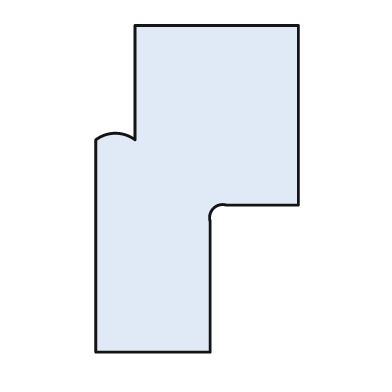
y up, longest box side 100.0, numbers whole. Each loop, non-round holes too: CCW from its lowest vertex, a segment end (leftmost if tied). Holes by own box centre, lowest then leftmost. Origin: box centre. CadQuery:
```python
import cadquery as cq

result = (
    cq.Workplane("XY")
    .moveTo(-31.0, -50.0)
    .lineTo(4.0, -50.0)
    .lineTo(4.0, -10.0)
    .threePointArc((5.0, -6.0), (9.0, -5.0))
    .lineTo(31.0, -5.0)
    .lineTo(31.0, 50.0)
    .lineTo(-19.0, 50.0)
    .lineTo(-19.0, 15.0)
    .threePointArc((-25.0, 17.0), (-31.0, 15.0))
    .close()
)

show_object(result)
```